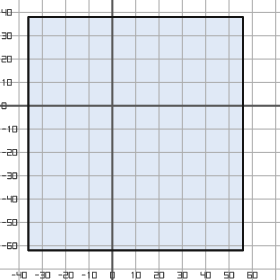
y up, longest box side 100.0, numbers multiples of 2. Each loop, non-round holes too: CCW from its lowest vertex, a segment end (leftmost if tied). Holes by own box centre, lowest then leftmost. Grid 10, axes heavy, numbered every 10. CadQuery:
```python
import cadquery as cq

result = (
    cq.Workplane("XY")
    .moveTo(-36.0, -62.0)
    .lineTo(56.0, -62.0)
    .lineTo(56.0, 38.0)
    .lineTo(-36.0, 38.0)
    .close()
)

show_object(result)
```